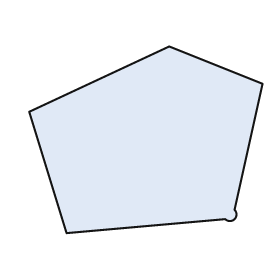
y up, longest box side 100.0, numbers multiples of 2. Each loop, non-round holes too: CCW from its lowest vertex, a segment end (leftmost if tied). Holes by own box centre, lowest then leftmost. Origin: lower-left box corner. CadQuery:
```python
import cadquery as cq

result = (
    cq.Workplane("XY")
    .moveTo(16.0, 0.0)
    .lineTo(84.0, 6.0)
    .threePointArc((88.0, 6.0), (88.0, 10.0))
    .lineTo(100.0, 64.0)
    .lineTo(60.0, 80.0)
    .lineTo(0.0, 52.0)
    .close()
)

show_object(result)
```